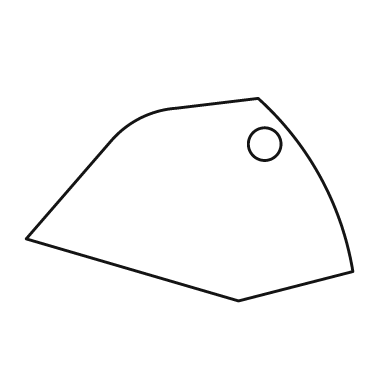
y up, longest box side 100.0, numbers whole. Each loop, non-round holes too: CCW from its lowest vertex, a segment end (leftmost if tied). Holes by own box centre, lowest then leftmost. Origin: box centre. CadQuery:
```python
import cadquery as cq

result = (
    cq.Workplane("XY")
    .moveTo(15.0, -31.0)
    .lineTo(50.0, -22.0)
    .threePointArc((40.0, 7.0), (21.0, 31.0))
    .lineTo(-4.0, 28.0)
    .threePointArc((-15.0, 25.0), (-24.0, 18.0))
    .lineTo(-50.0, -12.0)
    .close()
    .moveTo(23.0, 17.0)
    .circle(5.0)
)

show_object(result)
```